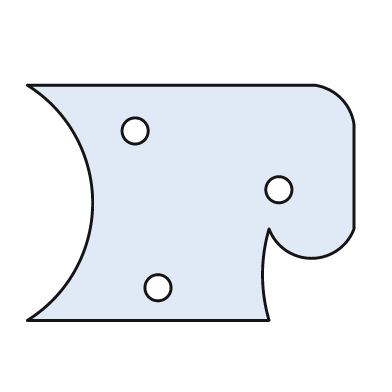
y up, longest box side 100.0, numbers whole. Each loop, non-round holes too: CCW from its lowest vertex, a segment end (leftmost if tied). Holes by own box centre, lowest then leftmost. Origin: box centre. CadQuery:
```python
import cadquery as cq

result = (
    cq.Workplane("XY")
    .moveTo(-50.0, -36.0)
    .lineTo(24.0, -36.0)
    .threePointArc((22.0, -22.0), (24.0, -8.0))
    .threePointArc((37.0, -17.0), (50.0, -8.0))
    .lineTo(50.0, 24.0)
    .threePointArc((46.0, 32.0), (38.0, 36.0))
    .lineTo(-50.0, 36.0)
    .threePointArc((-30.0, 0.0), (-50.0, -36.0))
    .close()
    .moveTo(-10.0, -26.0)
    .circle(4.0)
    .moveTo(27.0, 4.0)
    .circle(4.0)
    .moveTo(-17.0, 22.0)
    .circle(4.0)
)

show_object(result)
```